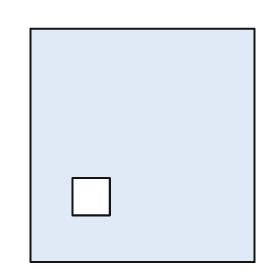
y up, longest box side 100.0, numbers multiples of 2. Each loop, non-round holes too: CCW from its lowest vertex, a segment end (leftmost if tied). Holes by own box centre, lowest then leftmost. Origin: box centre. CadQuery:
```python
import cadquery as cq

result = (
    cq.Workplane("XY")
    .moveTo(-48.0, -50.0)
    .lineTo(48.0, -50.0)
    .lineTo(48.0, 50.0)
    .lineTo(-48.0, 50.0)
    .close()
    .moveTo(-30.0, -30.0)
    .lineTo(-14.0, -30.0)
    .lineTo(-14.0, -14.0)
    .lineTo(-30.0, -14.0)
    .close()
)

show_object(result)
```